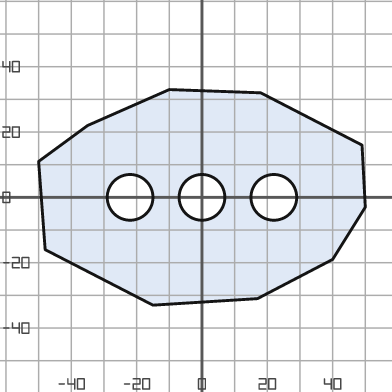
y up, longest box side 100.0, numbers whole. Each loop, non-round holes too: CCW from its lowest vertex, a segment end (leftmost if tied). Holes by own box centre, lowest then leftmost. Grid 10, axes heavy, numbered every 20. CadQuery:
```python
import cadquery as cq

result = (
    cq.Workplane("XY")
    .moveTo(-15.0, -33.0)
    .lineTo(17.0, -31.0)
    .lineTo(40.0, -19.0)
    .lineTo(50.0, -3.0)
    .lineTo(49.0, 16.0)
    .lineTo(18.0, 32.0)
    .lineTo(-10.0, 33.0)
    .lineTo(-35.0, 22.0)
    .lineTo(-50.0, 11.0)
    .lineTo(-48.0, -16.0)
    .close()
    .moveTo(-22.0, 0.0)
    .circle(7.0)
    .moveTo(0.0, 0.0)
    .circle(7.0)
    .moveTo(22.0, 0.0)
    .circle(7.0)
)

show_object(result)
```